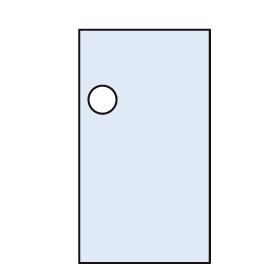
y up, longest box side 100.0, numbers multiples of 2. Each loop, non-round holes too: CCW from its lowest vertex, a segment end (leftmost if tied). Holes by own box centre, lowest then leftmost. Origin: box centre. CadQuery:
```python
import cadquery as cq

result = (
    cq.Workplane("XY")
    .moveTo(-28.0, -50.0)
    .lineTo(28.0, -50.0)
    .lineTo(28.0, 50.0)
    .lineTo(-28.0, 50.0)
    .close()
    .moveTo(-18.0, 20.0)
    .circle(6.0)
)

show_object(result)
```